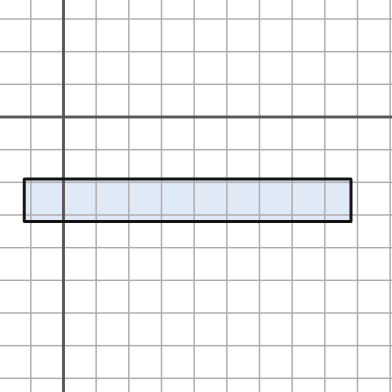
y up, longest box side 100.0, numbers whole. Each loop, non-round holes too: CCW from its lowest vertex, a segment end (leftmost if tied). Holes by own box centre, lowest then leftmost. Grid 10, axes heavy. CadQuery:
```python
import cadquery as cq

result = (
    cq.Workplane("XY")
    .moveTo(-12.0, -32.0)
    .lineTo(88.0, -32.0)
    .lineTo(88.0, -19.0)
    .lineTo(-12.0, -19.0)
    .close()
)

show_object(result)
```